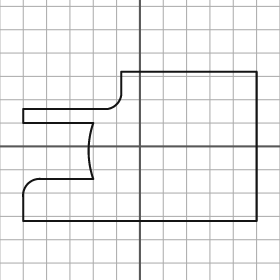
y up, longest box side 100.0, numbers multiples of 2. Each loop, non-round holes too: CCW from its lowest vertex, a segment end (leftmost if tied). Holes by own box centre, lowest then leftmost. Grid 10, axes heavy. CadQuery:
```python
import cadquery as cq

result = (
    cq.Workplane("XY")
    .moveTo(-50.0, -32.0)
    .lineTo(50.0, -32.0)
    .lineTo(50.0, 32.0)
    .lineTo(-8.0, 32.0)
    .lineTo(-8.0, 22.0)
    .threePointArc((-10.0, 18.0), (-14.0, 16.0))
    .lineTo(-50.0, 16.0)
    .lineTo(-50.0, 10.0)
    .lineTo(-20.0, 10.0)
    .threePointArc((-22.0, -2.0), (-20.0, -14.0))
    .lineTo(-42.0, -14.0)
    .threePointArc((-48.0, -16.0), (-50.0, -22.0))
    .close()
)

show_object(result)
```